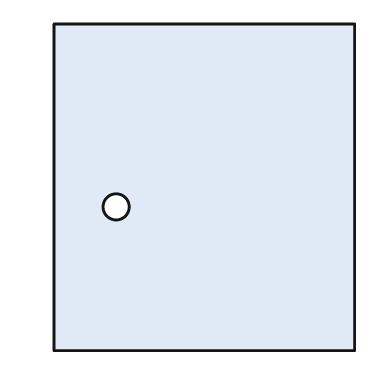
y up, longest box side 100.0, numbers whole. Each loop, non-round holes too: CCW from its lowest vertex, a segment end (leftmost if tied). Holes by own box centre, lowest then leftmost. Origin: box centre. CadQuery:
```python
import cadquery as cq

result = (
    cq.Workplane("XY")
    .moveTo(-46.0, -50.0)
    .lineTo(46.0, -50.0)
    .lineTo(46.0, 50.0)
    .lineTo(-46.0, 50.0)
    .close()
    .moveTo(-27.0, -6.0)
    .circle(4.0)
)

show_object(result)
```